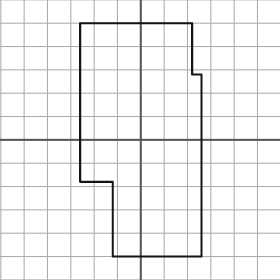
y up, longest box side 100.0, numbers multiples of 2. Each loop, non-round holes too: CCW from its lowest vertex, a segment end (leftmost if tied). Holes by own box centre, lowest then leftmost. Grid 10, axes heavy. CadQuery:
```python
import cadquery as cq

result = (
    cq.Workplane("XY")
    .moveTo(-12.0, -50.0)
    .lineTo(26.0, -50.0)
    .lineTo(26.0, 28.0)
    .lineTo(22.0, 28.0)
    .lineTo(22.0, 50.0)
    .lineTo(-26.0, 50.0)
    .lineTo(-26.0, -18.0)
    .lineTo(-12.0, -18.0)
    .close()
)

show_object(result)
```